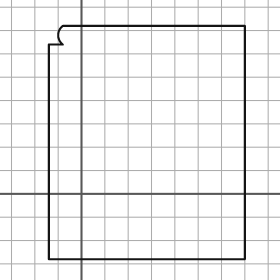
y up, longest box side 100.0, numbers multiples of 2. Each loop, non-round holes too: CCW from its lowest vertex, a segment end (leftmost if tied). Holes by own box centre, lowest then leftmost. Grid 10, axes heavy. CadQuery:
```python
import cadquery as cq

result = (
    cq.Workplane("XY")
    .moveTo(-14.0, -28.0)
    .lineTo(70.0, -28.0)
    .lineTo(70.0, 72.0)
    .lineTo(-8.0, 72.0)
    .threePointArc((-10.0, 68.0), (-8.0, 64.0))
    .lineTo(-14.0, 64.0)
    .close()
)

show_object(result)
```